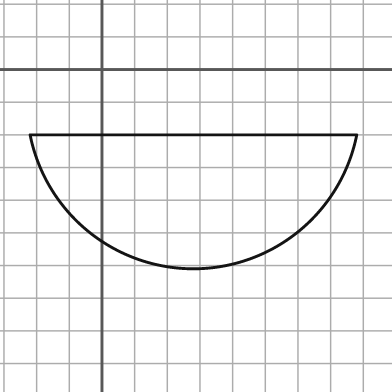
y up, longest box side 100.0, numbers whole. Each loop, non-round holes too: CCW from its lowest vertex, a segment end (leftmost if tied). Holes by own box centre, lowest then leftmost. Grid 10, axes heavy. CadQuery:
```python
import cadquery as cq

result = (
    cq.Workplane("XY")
    .moveTo(-22.0, -20.0)
    .threePointArc((28.0, -61.0), (78.0, -20.0))
    .close()
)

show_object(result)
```